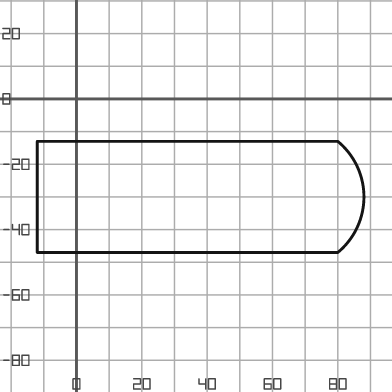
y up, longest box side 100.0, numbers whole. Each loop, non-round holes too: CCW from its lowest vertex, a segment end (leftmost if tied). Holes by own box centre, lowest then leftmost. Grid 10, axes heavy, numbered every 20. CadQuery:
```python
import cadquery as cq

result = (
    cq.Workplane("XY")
    .moveTo(-12.0, -47.0)
    .lineTo(80.0, -47.0)
    .threePointArc((88.0, -30.0), (80.0, -13.0))
    .lineTo(-12.0, -13.0)
    .close()
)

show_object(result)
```